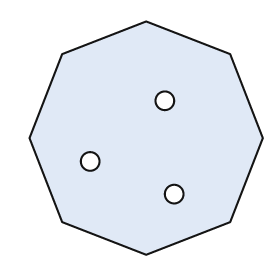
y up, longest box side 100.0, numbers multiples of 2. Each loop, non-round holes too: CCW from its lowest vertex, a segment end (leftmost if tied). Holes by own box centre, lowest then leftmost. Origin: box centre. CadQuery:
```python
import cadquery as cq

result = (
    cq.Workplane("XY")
    .moveTo(0.0, -50.0)
    .lineTo(36.0, -36.0)
    .lineTo(50.0, 0.0)
    .lineTo(36.0, 36.0)
    .lineTo(0.0, 50.0)
    .lineTo(-36.0, 36.0)
    .lineTo(-50.0, 0.0)
    .lineTo(-36.0, -36.0)
    .close()
    .moveTo(12.0, -24.0)
    .circle(4.0)
    .moveTo(-24.0, -10.0)
    .circle(4.0)
    .moveTo(8.0, 16.0)
    .circle(4.0)
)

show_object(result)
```